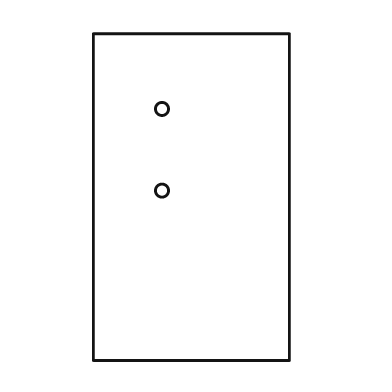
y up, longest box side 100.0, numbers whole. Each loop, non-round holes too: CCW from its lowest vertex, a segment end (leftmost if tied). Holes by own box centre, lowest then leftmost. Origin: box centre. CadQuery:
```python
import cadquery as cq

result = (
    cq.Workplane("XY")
    .moveTo(-30.0, -50.0)
    .lineTo(30.0, -50.0)
    .lineTo(30.0, 50.0)
    .lineTo(-30.0, 50.0)
    .close()
    .moveTo(-9.0, 2.0)
    .circle(2.0)
    .moveTo(-9.0, 27.0)
    .circle(2.0)
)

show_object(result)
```